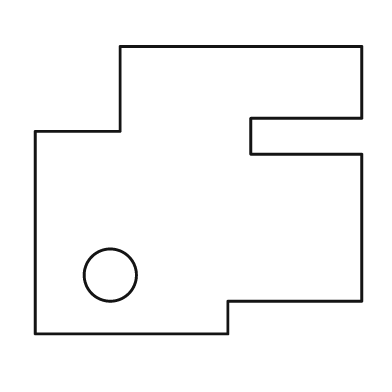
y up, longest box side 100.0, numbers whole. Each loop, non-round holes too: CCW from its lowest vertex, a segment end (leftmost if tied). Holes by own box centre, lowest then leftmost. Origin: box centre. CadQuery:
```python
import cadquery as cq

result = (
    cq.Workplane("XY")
    .moveTo(-50.0, -44.0)
    .lineTo(9.0, -44.0)
    .lineTo(9.0, -34.0)
    .lineTo(50.0, -34.0)
    .lineTo(50.0, 11.0)
    .lineTo(16.0, 11.0)
    .lineTo(16.0, 22.0)
    .lineTo(50.0, 22.0)
    .lineTo(50.0, 44.0)
    .lineTo(-24.0, 44.0)
    .lineTo(-24.0, 18.0)
    .lineTo(-50.0, 18.0)
    .close()
    .moveTo(-27.0, -26.0)
    .circle(8.0)
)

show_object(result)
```